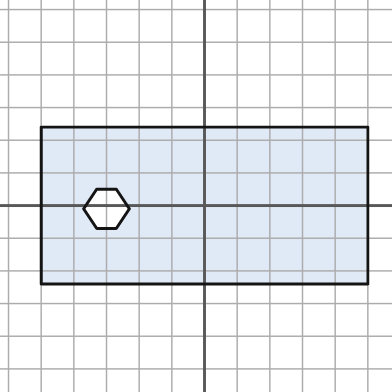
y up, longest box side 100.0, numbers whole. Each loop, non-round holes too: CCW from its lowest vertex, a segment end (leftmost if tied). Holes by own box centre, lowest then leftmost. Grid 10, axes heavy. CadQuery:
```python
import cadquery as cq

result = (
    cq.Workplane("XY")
    .moveTo(-50.0, -24.0)
    .lineTo(50.0, -24.0)
    .lineTo(50.0, 24.0)
    .lineTo(-50.0, 24.0)
    .close()
    .moveTo(-33.0, -7.0)
    .lineTo(-27.0, -7.0)
    .lineTo(-23.0, -1.0)
    .lineTo(-27.0, 5.0)
    .lineTo(-33.0, 5.0)
    .lineTo(-37.0, -1.0)
    .close()
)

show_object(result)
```